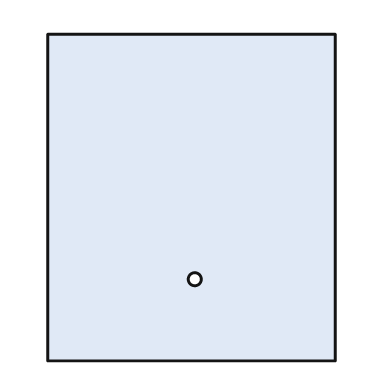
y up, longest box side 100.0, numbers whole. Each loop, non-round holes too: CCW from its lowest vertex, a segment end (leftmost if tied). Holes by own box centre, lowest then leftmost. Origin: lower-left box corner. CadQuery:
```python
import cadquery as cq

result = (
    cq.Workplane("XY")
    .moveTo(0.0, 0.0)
    .lineTo(88.0, 0.0)
    .lineTo(88.0, 100.0)
    .lineTo(0.0, 100.0)
    .close()
    .moveTo(45.0, 25.0)
    .circle(2.0)
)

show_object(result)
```